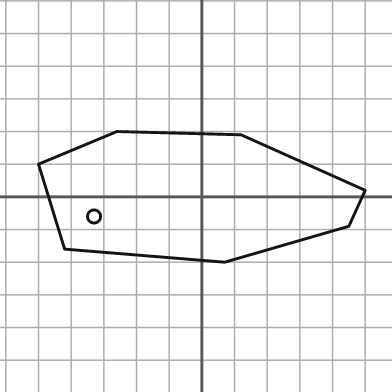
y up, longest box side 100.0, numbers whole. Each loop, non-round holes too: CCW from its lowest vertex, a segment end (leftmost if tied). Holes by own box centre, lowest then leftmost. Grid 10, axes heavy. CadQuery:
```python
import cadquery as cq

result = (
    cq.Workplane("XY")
    .moveTo(7.0, -20.0)
    .lineTo(45.0, -9.0)
    .lineTo(50.0, 2.0)
    .lineTo(12.0, 19.0)
    .lineTo(-26.0, 20.0)
    .lineTo(-50.0, 10.0)
    .lineTo(-42.0, -16.0)
    .close()
    .moveTo(-33.0, -6.0)
    .circle(2.0)
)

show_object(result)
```